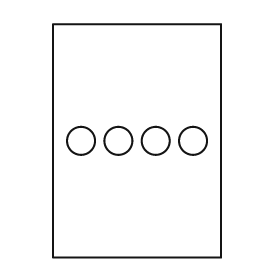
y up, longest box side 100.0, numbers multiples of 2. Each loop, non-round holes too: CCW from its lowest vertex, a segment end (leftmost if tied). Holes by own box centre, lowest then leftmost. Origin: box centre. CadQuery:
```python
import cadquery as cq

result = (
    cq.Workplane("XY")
    .moveTo(-36.0, -50.0)
    .lineTo(36.0, -50.0)
    .lineTo(36.0, 50.0)
    .lineTo(-36.0, 50.0)
    .close()
    .moveTo(-24.0, 0.0)
    .circle(6.0)
    .moveTo(-8.0, 0.0)
    .circle(6.0)
    .moveTo(8.0, 0.0)
    .circle(6.0)
    .moveTo(24.0, 0.0)
    .circle(6.0)
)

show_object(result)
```